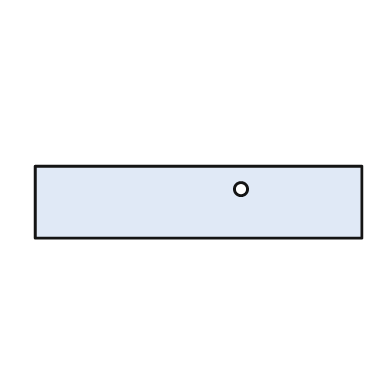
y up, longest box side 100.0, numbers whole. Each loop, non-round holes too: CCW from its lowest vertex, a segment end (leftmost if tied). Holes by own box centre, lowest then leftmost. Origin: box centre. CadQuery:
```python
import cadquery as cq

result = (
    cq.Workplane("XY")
    .moveTo(-50.0, -11.0)
    .lineTo(50.0, -11.0)
    .lineTo(50.0, 11.0)
    .lineTo(-50.0, 11.0)
    .close()
    .moveTo(13.0, 4.0)
    .circle(2.0)
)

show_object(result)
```